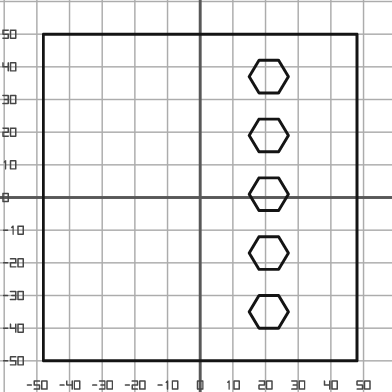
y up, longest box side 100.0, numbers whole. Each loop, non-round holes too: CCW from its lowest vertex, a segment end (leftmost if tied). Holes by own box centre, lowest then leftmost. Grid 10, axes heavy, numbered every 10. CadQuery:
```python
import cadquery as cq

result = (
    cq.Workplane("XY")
    .moveTo(-48.0, -50.0)
    .lineTo(48.0, -50.0)
    .lineTo(48.0, 50.0)
    .lineTo(-48.0, 50.0)
    .close()
    .moveTo(18.0, -40.0)
    .lineTo(24.0, -40.0)
    .lineTo(27.0, -35.0)
    .lineTo(24.0, -30.0)
    .lineTo(18.0, -30.0)
    .lineTo(15.0, -35.0)
    .close()
    .moveTo(18.0, -22.0)
    .lineTo(24.0, -22.0)
    .lineTo(27.0, -17.0)
    .lineTo(24.0, -12.0)
    .lineTo(18.0, -12.0)
    .lineTo(15.0, -17.0)
    .close()
    .moveTo(18.0, -4.0)
    .lineTo(24.0, -4.0)
    .lineTo(27.0, 1.0)
    .lineTo(24.0, 6.0)
    .lineTo(18.0, 6.0)
    .lineTo(15.0, 1.0)
    .close()
    .moveTo(18.0, 14.0)
    .lineTo(24.0, 14.0)
    .lineTo(27.0, 19.0)
    .lineTo(24.0, 24.0)
    .lineTo(18.0, 24.0)
    .lineTo(15.0, 19.0)
    .close()
    .moveTo(18.0, 32.0)
    .lineTo(24.0, 32.0)
    .lineTo(27.0, 37.0)
    .lineTo(24.0, 42.0)
    .lineTo(18.0, 42.0)
    .lineTo(15.0, 37.0)
    .close()
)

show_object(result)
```